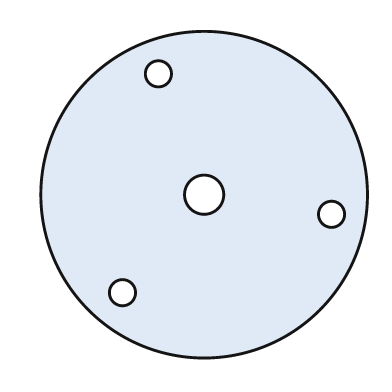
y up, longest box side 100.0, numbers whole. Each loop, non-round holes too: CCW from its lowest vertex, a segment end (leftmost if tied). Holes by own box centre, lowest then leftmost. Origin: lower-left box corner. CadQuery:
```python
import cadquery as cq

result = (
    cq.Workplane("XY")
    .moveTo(50.0, 50.0)
    .circle(50.0)
    .moveTo(25.0, 20.0)
    .circle(4.0)
    .moveTo(89.0, 44.0)
    .circle(4.0)
    .moveTo(50.0, 50.0)
    .circle(6.0)
    .moveTo(36.0, 87.0)
    .circle(4.0)
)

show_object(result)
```